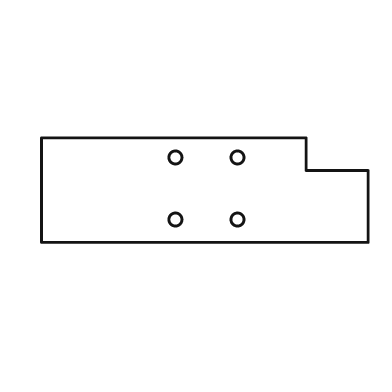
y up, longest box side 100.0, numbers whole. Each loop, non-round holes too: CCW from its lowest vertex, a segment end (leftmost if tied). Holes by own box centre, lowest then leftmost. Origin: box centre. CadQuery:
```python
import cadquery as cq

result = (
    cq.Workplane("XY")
    .moveTo(-50.0, -16.0)
    .lineTo(50.0, -16.0)
    .lineTo(50.0, 6.0)
    .lineTo(31.0, 6.0)
    .lineTo(31.0, 16.0)
    .lineTo(-50.0, 16.0)
    .close()
    .moveTo(-9.0, -9.0)
    .circle(2.0)
    .moveTo(10.0, -9.0)
    .circle(2.0)
    .moveTo(-9.0, 10.0)
    .circle(2.0)
    .moveTo(10.0, 10.0)
    .circle(2.0)
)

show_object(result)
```